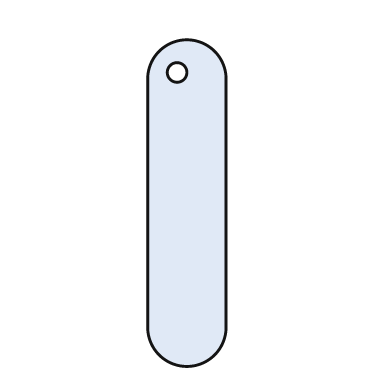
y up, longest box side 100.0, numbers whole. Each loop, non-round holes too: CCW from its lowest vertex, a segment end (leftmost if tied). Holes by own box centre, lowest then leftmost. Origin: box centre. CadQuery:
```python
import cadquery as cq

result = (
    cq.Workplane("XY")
    .moveTo(-12.0, -38.0)
    .threePointArc((0.0, -50.0), (12.0, -38.0))
    .lineTo(12.0, 38.0)
    .threePointArc((0.0, 50.0), (-12.0, 38.0))
    .close()
    .moveTo(-3.0, 40.0)
    .circle(3.0)
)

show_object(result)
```